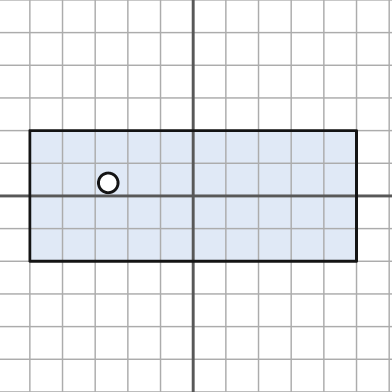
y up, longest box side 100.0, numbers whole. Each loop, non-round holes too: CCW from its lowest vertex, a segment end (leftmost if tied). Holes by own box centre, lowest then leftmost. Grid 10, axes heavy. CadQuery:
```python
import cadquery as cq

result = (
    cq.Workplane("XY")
    .moveTo(-50.0, -20.0)
    .lineTo(50.0, -20.0)
    .lineTo(50.0, 20.0)
    .lineTo(-50.0, 20.0)
    .close()
    .moveTo(-26.0, 4.0)
    .circle(3.0)
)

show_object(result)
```